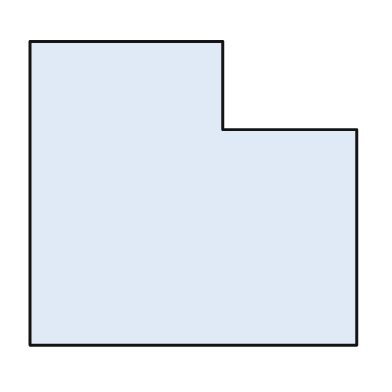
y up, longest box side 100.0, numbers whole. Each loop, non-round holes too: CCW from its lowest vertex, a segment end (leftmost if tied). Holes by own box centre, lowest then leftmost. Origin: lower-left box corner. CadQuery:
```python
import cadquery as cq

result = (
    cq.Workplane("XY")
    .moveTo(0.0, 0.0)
    .lineTo(100.0, 0.0)
    .lineTo(100.0, 66.0)
    .lineTo(59.0, 66.0)
    .lineTo(59.0, 93.0)
    .lineTo(0.0, 93.0)
    .close()
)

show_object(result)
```